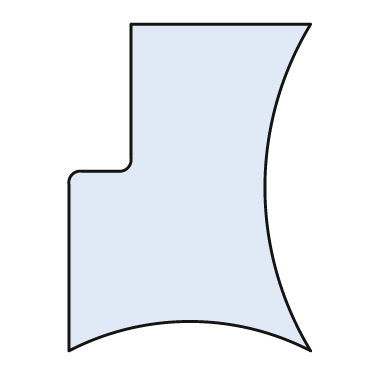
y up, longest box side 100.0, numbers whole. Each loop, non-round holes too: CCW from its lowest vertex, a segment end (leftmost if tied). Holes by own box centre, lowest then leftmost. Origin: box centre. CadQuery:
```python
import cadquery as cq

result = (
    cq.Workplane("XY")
    .moveTo(-37.0, -50.0)
    .threePointArc((0.0, -41.0), (37.0, -50.0))
    .threePointArc((23.0, 0.0), (37.0, 50.0))
    .lineTo(-18.0, 50.0)
    .lineTo(-18.0, 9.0)
    .threePointArc((-19.0, 6.0), (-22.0, 5.0))
    .lineTo(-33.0, 5.0)
    .threePointArc((-36.0, 4.0), (-37.0, 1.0))
    .close()
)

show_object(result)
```